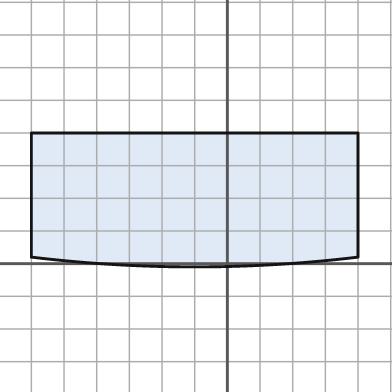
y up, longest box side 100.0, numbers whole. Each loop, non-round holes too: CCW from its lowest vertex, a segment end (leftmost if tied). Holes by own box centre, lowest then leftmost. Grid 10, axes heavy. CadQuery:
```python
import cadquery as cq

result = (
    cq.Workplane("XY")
    .moveTo(-60.0, 2.0)
    .threePointArc((-10.0, -1.0), (40.0, 2.0))
    .lineTo(40.0, 40.0)
    .lineTo(-60.0, 40.0)
    .close()
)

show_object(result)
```